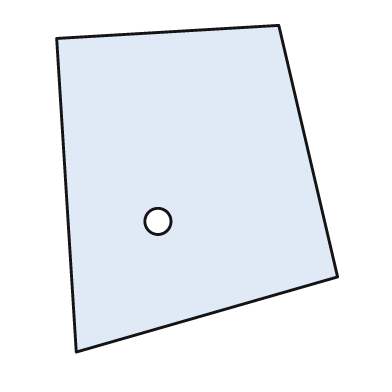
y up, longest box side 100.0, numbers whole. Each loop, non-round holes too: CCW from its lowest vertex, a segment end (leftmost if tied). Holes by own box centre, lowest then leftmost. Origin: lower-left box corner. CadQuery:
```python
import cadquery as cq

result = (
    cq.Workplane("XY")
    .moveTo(6.0, 0.0)
    .lineTo(86.0, 23.0)
    .lineTo(68.0, 100.0)
    .lineTo(0.0, 96.0)
    .close()
    .moveTo(31.0, 40.0)
    .circle(4.0)
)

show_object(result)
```